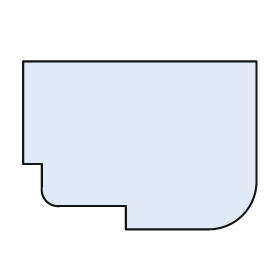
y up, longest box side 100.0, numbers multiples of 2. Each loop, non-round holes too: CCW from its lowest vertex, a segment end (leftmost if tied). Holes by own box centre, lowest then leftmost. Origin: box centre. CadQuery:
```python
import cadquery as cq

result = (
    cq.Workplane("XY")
    .moveTo(-6.0, -36.0)
    .lineTo(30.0, -36.0)
    .threePointArc((44.0, -30.0), (50.0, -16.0))
    .lineTo(50.0, 36.0)
    .lineTo(-50.0, 36.0)
    .lineTo(-50.0, -8.0)
    .lineTo(-42.0, -8.0)
    .lineTo(-42.0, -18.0)
    .threePointArc((-40.0, -24.0), (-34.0, -26.0))
    .lineTo(-6.0, -26.0)
    .close()
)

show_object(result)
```